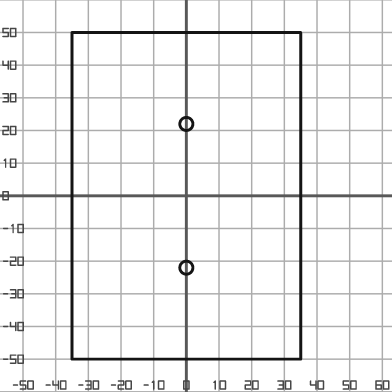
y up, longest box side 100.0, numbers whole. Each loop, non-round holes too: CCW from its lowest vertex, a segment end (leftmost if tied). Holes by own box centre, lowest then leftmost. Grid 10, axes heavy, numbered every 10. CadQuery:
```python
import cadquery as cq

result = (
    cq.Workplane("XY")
    .moveTo(-35.0, -50.0)
    .lineTo(35.0, -50.0)
    .lineTo(35.0, 50.0)
    .lineTo(-35.0, 50.0)
    .close()
    .moveTo(0.0, -22.0)
    .circle(2.0)
    .moveTo(0.0, 22.0)
    .circle(2.0)
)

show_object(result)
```